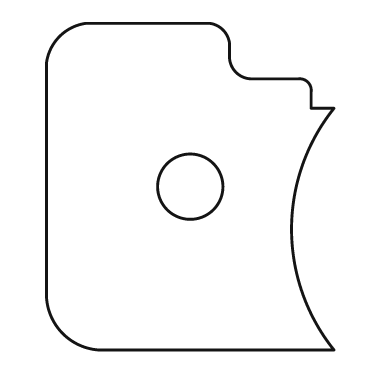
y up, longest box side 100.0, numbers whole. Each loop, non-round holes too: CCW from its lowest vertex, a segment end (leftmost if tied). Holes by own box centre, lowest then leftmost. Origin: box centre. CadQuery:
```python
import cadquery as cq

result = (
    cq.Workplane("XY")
    .moveTo(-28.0, -50.0)
    .lineTo(44.0, -50.0)
    .threePointArc((31.0, -13.0), (44.0, 24.0))
    .lineTo(37.0, 24.0)
    .lineTo(37.0, 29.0)
    .threePointArc((36.0, 32.0), (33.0, 33.0))
    .lineTo(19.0, 33.0)
    .threePointArc((14.0, 35.0), (12.0, 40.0))
    .lineTo(12.0, 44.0)
    .threePointArc((10.0, 48.0), (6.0, 50.0))
    .lineTo(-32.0, 50.0)
    .threePointArc((-40.0, 46.0), (-44.0, 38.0))
    .lineTo(-44.0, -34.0)
    .threePointArc((-39.0, -45.0), (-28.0, -50.0))
    .close()
    .moveTo(0.0, 0.0)
    .circle(10.0)
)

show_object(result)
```